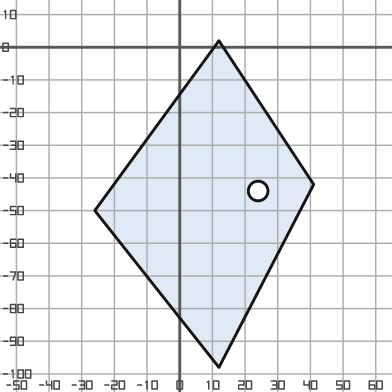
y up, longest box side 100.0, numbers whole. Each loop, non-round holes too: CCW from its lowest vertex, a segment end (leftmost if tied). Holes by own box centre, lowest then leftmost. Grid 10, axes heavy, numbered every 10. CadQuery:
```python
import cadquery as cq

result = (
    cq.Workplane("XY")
    .moveTo(12.0, -98.0)
    .lineTo(41.0, -42.0)
    .lineTo(12.0, 2.0)
    .lineTo(-26.0, -50.0)
    .close()
    .moveTo(24.0, -44.0)
    .circle(3.0)
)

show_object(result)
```